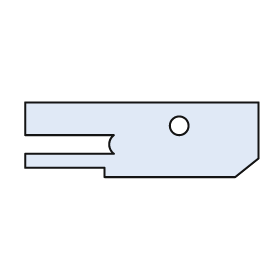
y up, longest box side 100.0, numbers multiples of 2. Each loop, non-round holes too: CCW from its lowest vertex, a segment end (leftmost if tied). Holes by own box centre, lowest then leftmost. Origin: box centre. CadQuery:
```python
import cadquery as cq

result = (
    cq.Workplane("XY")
    .moveTo(-16.0, -16.0)
    .lineTo(40.0, -16.0)
    .lineTo(50.0, -8.0)
    .lineTo(50.0, 16.0)
    .lineTo(-50.0, 16.0)
    .lineTo(-50.0, 2.0)
    .lineTo(-12.0, 2.0)
    .threePointArc((-14.0, -2.0), (-12.0, -6.0))
    .lineTo(-50.0, -6.0)
    .lineTo(-50.0, -12.0)
    .lineTo(-16.0, -12.0)
    .close()
    .moveTo(16.0, 6.0)
    .circle(4.0)
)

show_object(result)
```